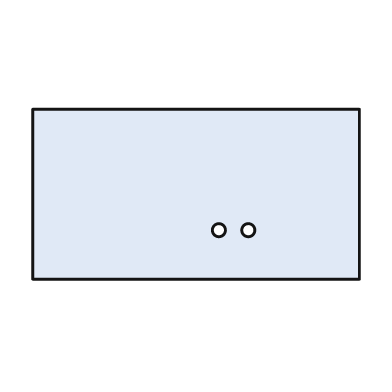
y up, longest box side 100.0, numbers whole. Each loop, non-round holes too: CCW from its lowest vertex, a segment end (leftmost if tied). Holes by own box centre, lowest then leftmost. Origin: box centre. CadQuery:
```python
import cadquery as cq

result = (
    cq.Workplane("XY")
    .moveTo(-50.0, -26.0)
    .lineTo(50.0, -26.0)
    .lineTo(50.0, 26.0)
    .lineTo(-50.0, 26.0)
    .close()
    .moveTo(7.0, -11.0)
    .circle(2.0)
    .moveTo(16.0, -11.0)
    .circle(2.0)
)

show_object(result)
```